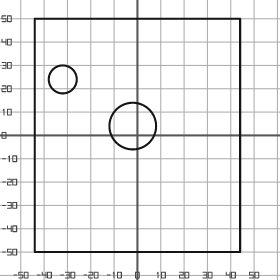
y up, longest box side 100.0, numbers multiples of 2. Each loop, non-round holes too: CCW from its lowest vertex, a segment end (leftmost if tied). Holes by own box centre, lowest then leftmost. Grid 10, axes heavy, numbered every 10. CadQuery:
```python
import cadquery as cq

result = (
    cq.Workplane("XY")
    .moveTo(-44.0, -50.0)
    .lineTo(44.0, -50.0)
    .lineTo(44.0, 50.0)
    .lineTo(-44.0, 50.0)
    .close()
    .moveTo(-2.0, 4.0)
    .circle(10.0)
    .moveTo(-32.0, 24.0)
    .circle(6.0)
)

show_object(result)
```